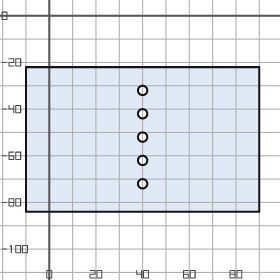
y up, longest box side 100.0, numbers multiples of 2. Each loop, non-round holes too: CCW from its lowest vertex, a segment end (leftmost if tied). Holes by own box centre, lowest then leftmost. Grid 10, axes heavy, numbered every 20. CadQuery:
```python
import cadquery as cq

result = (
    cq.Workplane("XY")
    .moveTo(-10.0, -84.0)
    .lineTo(90.0, -84.0)
    .lineTo(90.0, -22.0)
    .lineTo(-10.0, -22.0)
    .close()
    .moveTo(40.0, -72.0)
    .circle(2.0)
    .moveTo(40.0, -62.0)
    .circle(2.0)
    .moveTo(40.0, -52.0)
    .circle(2.0)
    .moveTo(40.0, -42.0)
    .circle(2.0)
    .moveTo(40.0, -32.0)
    .circle(2.0)
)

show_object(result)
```